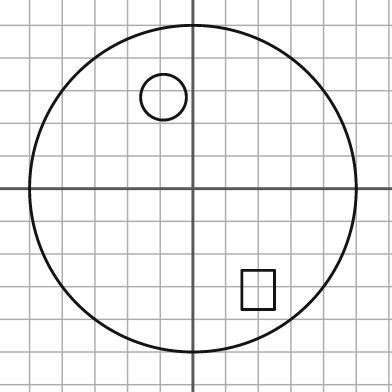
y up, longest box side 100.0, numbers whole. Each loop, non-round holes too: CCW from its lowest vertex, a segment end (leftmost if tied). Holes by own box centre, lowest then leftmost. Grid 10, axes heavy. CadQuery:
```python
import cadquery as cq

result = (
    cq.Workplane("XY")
    .moveTo(0.0, 0.0)
    .circle(50.0)
    .moveTo(15.0, -37.0)
    .lineTo(25.0, -37.0)
    .lineTo(25.0, -25.0)
    .lineTo(15.0, -25.0)
    .close()
    .moveTo(-9.0, 28.0)
    .circle(7.0)
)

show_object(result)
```